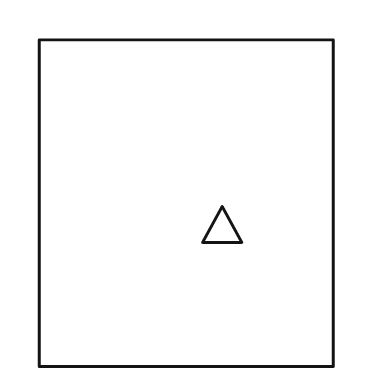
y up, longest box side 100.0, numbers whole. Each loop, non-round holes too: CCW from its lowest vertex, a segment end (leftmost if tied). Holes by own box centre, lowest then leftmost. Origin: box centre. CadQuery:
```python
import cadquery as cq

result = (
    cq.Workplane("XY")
    .moveTo(-45.0, -50.0)
    .lineTo(45.0, -50.0)
    .lineTo(45.0, 50.0)
    .lineTo(-45.0, 50.0)
    .close()
    .moveTo(5.0, -12.0)
    .lineTo(17.0, -12.0)
    .lineTo(11.0, -1.0)
    .close()
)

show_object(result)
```